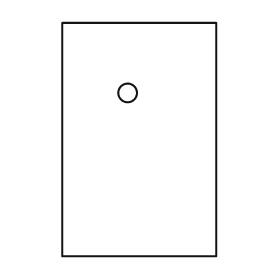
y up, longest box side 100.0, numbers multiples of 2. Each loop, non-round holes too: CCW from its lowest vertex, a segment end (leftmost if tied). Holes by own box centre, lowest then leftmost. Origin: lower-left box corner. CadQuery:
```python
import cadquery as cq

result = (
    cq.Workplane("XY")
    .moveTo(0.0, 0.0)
    .lineTo(66.0, 0.0)
    .lineTo(66.0, 100.0)
    .lineTo(0.0, 100.0)
    .close()
    .moveTo(28.0, 70.0)
    .circle(4.0)
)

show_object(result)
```